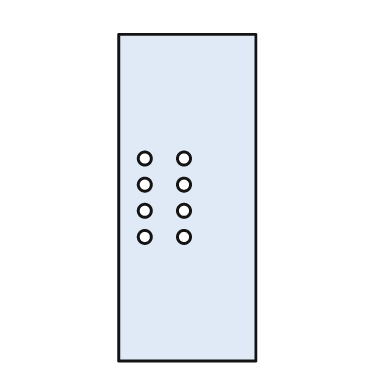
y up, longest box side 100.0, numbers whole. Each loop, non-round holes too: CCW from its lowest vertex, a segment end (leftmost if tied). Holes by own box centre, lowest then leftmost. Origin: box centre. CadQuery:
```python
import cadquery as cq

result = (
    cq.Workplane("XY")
    .moveTo(-21.0, -50.0)
    .lineTo(21.0, -50.0)
    .lineTo(21.0, 50.0)
    .lineTo(-21.0, 50.0)
    .close()
    .moveTo(-13.0, -12.0)
    .circle(2.0)
    .moveTo(-1.0, -12.0)
    .circle(2.0)
    .moveTo(-13.0, -4.0)
    .circle(2.0)
    .moveTo(-1.0, -4.0)
    .circle(2.0)
    .moveTo(-13.0, 4.0)
    .circle(2.0)
    .moveTo(-1.0, 4.0)
    .circle(2.0)
    .moveTo(-13.0, 12.0)
    .circle(2.0)
    .moveTo(-1.0, 12.0)
    .circle(2.0)
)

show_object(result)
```